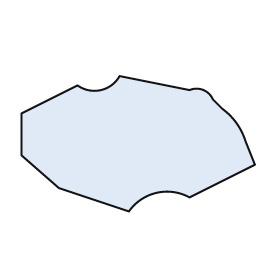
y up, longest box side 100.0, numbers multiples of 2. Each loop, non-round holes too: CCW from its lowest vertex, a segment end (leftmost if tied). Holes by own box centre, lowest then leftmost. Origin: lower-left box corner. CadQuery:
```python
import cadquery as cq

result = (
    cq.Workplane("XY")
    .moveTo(46.0, 0.0)
    .threePointArc((58.0, 8.0), (72.0, 6.0))
    .lineTo(100.0, 20.0)
    .lineTo(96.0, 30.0)
    .threePointArc((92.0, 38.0), (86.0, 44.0))
    .lineTo(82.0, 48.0)
    .threePointArc((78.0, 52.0), (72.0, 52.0))
    .lineTo(42.0, 58.0)
    .threePointArc((34.0, 52.0), (24.0, 54.0))
    .lineTo(0.0, 42.0)
    .lineTo(0.0, 24.0)
    .lineTo(16.0, 10.0)
    .close()
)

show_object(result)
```